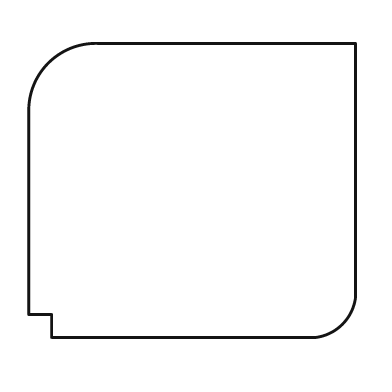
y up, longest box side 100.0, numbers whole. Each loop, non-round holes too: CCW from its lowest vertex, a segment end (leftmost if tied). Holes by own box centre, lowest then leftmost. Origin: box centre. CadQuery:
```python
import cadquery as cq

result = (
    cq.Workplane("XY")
    .moveTo(-43.0, -45.0)
    .lineTo(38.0, -45.0)
    .threePointArc((46.0, -41.0), (50.0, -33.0))
    .lineTo(50.0, 45.0)
    .lineTo(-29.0, 45.0)
    .threePointArc((-44.0, 39.0), (-50.0, 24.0))
    .lineTo(-50.0, -38.0)
    .lineTo(-43.0, -38.0)
    .close()
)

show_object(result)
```